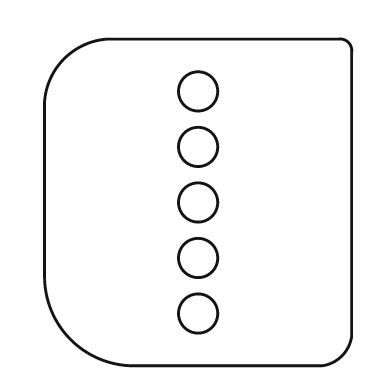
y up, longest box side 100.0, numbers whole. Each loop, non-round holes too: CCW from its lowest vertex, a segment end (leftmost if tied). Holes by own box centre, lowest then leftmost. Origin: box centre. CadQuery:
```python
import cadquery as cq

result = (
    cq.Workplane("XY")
    .moveTo(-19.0, -50.0)
    .lineTo(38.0, -50.0)
    .threePointArc((44.0, -47.0), (47.0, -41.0))
    .lineTo(47.0, 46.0)
    .threePointArc((46.0, 49.0), (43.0, 50.0))
    .lineTo(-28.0, 50.0)
    .threePointArc((-41.0, 44.0), (-47.0, 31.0))
    .lineTo(-47.0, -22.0)
    .threePointArc((-39.0, -42.0), (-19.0, -50.0))
    .close()
    .moveTo(0.0, -34.0)
    .circle(6.0)
    .moveTo(0.0, -17.0)
    .circle(6.0)
    .moveTo(0.0, 0.0)
    .circle(6.0)
    .moveTo(0.0, 17.0)
    .circle(6.0)
    .moveTo(0.0, 34.0)
    .circle(6.0)
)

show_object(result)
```